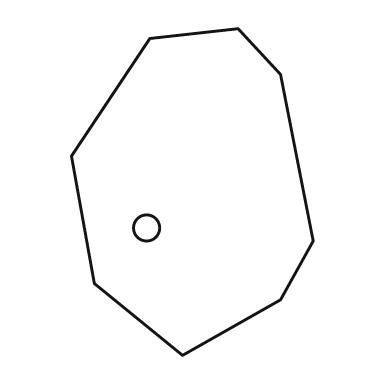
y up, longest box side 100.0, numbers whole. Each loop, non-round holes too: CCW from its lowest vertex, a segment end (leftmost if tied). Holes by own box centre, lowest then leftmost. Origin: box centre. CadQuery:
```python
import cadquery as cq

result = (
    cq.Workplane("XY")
    .moveTo(-3.0, -50.0)
    .lineTo(27.0, -33.0)
    .lineTo(37.0, -15.0)
    .lineTo(27.0, 36.0)
    .lineTo(14.0, 50.0)
    .lineTo(-13.0, 47.0)
    .lineTo(-37.0, 11.0)
    .lineTo(-30.0, -28.0)
    .close()
    .moveTo(-14.0, -11.0)
    .circle(4.0)
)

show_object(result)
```